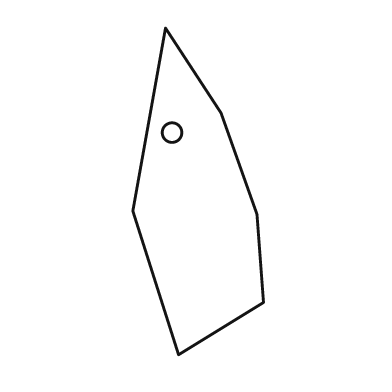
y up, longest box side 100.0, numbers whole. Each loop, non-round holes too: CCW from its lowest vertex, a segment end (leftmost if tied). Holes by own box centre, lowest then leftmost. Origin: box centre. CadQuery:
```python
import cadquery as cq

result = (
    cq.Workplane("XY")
    .moveTo(-6.0, -50.0)
    .lineTo(20.0, -34.0)
    .lineTo(18.0, -7.0)
    .lineTo(7.0, 24.0)
    .lineTo(-10.0, 50.0)
    .lineTo(-20.0, -6.0)
    .close()
    .moveTo(-8.0, 18.0)
    .circle(3.0)
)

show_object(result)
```